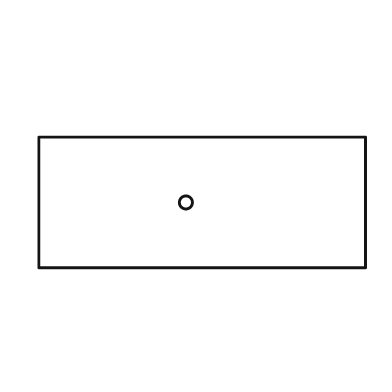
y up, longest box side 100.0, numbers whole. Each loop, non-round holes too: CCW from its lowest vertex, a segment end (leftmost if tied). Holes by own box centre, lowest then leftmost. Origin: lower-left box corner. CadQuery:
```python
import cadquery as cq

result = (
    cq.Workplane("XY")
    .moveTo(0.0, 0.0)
    .lineTo(100.0, 0.0)
    .lineTo(100.0, 40.0)
    .lineTo(0.0, 40.0)
    .close()
    .moveTo(45.0, 20.0)
    .circle(2.0)
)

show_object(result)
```